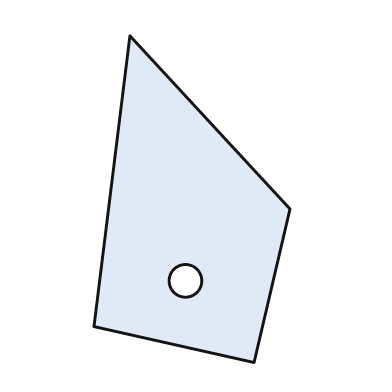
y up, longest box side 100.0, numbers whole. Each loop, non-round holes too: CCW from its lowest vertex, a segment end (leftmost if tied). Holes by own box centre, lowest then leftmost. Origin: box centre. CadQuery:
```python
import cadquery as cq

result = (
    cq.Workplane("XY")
    .moveTo(19.0, -50.0)
    .lineTo(30.0, -3.0)
    .lineTo(-19.0, 50.0)
    .lineTo(-30.0, -39.0)
    .close()
    .moveTo(-2.0, -25.0)
    .circle(5.0)
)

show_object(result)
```